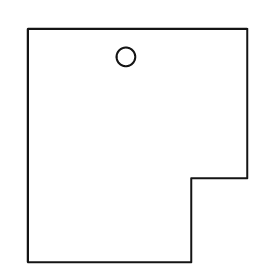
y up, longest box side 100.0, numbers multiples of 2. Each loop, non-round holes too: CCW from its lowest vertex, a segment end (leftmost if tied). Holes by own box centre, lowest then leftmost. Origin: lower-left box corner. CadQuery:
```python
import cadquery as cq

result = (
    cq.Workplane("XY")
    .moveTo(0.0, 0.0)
    .lineTo(70.0, 0.0)
    .lineTo(70.0, 36.0)
    .lineTo(94.0, 36.0)
    .lineTo(94.0, 100.0)
    .lineTo(0.0, 100.0)
    .close()
    .moveTo(42.0, 88.0)
    .circle(4.0)
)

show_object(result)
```